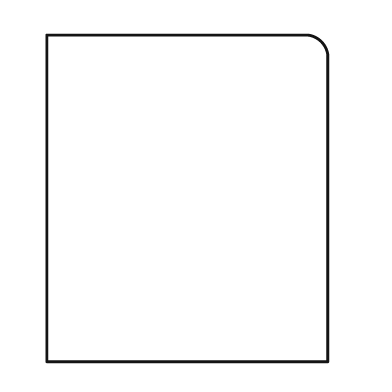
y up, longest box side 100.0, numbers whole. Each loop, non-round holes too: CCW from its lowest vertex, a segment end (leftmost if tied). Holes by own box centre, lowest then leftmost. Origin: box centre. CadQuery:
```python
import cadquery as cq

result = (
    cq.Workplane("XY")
    .moveTo(-43.0, -50.0)
    .lineTo(43.0, -50.0)
    .lineTo(43.0, 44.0)
    .threePointArc((41.0, 48.0), (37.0, 50.0))
    .lineTo(-43.0, 50.0)
    .close()
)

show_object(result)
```